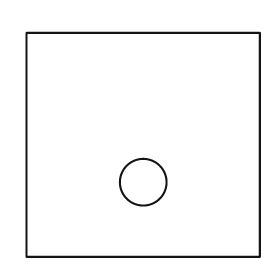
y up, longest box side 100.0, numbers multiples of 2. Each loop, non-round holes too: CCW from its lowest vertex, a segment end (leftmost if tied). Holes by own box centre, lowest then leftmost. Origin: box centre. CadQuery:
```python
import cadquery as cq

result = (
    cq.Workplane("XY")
    .moveTo(-50.0, -48.0)
    .lineTo(50.0, -48.0)
    .lineTo(50.0, 48.0)
    .lineTo(-50.0, 48.0)
    .close()
    .moveTo(0.0, -16.0)
    .circle(10.0)
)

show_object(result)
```